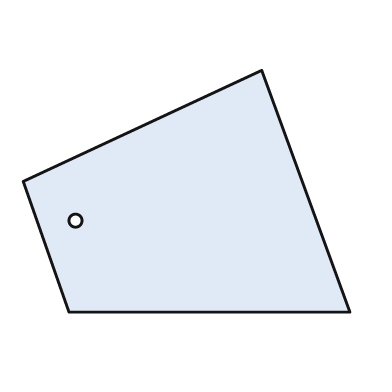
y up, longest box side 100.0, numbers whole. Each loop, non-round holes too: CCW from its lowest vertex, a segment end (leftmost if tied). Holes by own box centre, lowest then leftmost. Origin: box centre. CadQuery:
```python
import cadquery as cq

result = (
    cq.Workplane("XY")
    .moveTo(-36.0, -37.0)
    .lineTo(50.0, -37.0)
    .lineTo(23.0, 37.0)
    .lineTo(-50.0, 3.0)
    .close()
    .moveTo(-34.0, -9.0)
    .circle(2.0)
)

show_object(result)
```